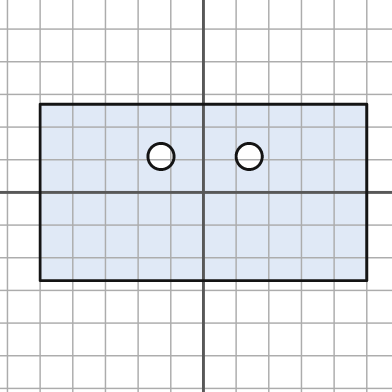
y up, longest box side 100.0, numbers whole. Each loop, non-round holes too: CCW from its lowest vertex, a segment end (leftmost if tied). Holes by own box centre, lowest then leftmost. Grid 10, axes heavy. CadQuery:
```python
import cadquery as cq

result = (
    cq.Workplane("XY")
    .moveTo(-50.0, -27.0)
    .lineTo(50.0, -27.0)
    .lineTo(50.0, 27.0)
    .lineTo(-50.0, 27.0)
    .close()
    .moveTo(-13.0, 11.0)
    .circle(4.0)
    .moveTo(14.0, 11.0)
    .circle(4.0)
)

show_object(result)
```